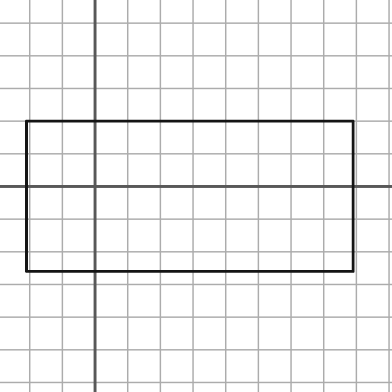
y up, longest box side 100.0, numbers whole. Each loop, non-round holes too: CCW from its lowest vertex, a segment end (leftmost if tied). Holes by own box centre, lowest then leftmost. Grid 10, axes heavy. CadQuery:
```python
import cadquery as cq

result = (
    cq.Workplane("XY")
    .moveTo(-21.0, -26.0)
    .lineTo(79.0, -26.0)
    .lineTo(79.0, 20.0)
    .lineTo(-21.0, 20.0)
    .close()
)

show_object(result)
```